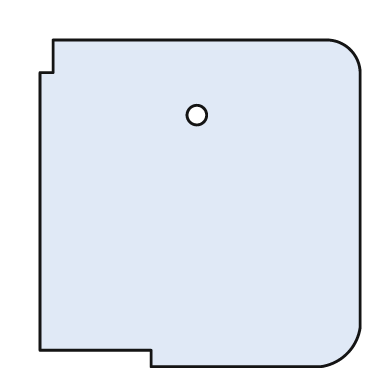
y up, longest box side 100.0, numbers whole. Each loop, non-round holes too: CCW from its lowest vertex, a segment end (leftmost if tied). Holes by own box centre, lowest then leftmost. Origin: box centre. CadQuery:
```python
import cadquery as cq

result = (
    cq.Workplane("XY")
    .moveTo(-15.0, -50.0)
    .lineTo(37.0, -50.0)
    .threePointArc((45.0, -46.0), (49.0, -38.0))
    .lineTo(49.0, 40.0)
    .threePointArc((46.0, 47.0), (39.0, 50.0))
    .lineTo(-45.0, 50.0)
    .lineTo(-45.0, 40.0)
    .lineTo(-49.0, 40.0)
    .lineTo(-49.0, -45.0)
    .lineTo(-15.0, -45.0)
    .close()
    .moveTo(-1.0, 27.0)
    .circle(3.0)
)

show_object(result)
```